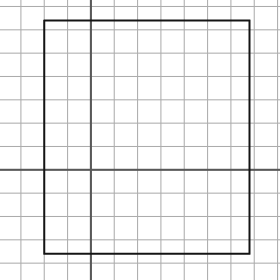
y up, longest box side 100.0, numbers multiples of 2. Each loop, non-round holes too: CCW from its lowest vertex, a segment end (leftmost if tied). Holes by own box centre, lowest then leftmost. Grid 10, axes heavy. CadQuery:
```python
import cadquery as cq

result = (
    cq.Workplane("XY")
    .moveTo(-20.0, -36.0)
    .lineTo(68.0, -36.0)
    .lineTo(68.0, 64.0)
    .lineTo(-20.0, 64.0)
    .close()
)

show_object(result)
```